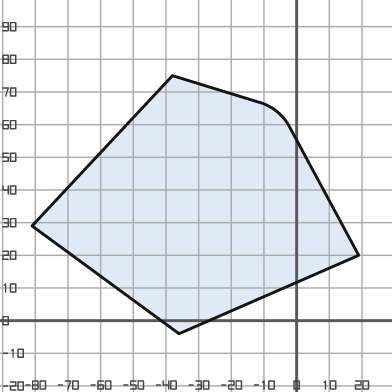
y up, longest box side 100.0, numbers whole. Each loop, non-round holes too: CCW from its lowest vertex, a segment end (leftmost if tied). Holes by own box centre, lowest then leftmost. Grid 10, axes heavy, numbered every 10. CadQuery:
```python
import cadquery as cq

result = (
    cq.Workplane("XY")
    .moveTo(-36.0, -4.0)
    .lineTo(19.0, 20.0)
    .lineTo(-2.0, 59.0)
    .threePointArc((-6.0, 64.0), (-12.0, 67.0))
    .lineTo(-38.0, 75.0)
    .lineTo(-81.0, 29.0)
    .close()
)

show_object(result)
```